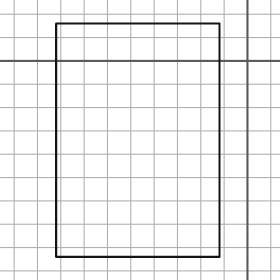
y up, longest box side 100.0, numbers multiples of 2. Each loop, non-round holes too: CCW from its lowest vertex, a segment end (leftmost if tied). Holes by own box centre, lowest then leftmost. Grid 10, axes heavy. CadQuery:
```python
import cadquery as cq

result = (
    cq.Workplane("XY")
    .moveTo(-82.0, -84.0)
    .lineTo(-12.0, -84.0)
    .lineTo(-12.0, 16.0)
    .lineTo(-82.0, 16.0)
    .close()
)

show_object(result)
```